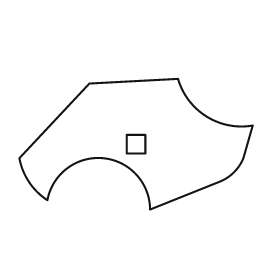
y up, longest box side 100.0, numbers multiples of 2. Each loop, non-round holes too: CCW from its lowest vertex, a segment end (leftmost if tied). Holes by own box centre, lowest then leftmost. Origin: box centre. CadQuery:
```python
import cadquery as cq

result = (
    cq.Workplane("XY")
    .moveTo(6.0, -28.0)
    .lineTo(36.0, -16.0)
    .threePointArc((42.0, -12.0), (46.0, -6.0))
    .lineTo(50.0, 8.0)
    .threePointArc((30.0, 12.0), (18.0, 28.0))
    .lineTo(-20.0, 26.0)
    .lineTo(-50.0, -6.0)
    .threePointArc((-46.0, -16.0), (-38.0, -24.0))
    .threePointArc((-14.0, -6.0), (6.0, -28.0))
    .close()
    .moveTo(-4.0, -4.0)
    .lineTo(4.0, -4.0)
    .lineTo(4.0, 4.0)
    .lineTo(-4.0, 4.0)
    .close()
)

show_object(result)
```